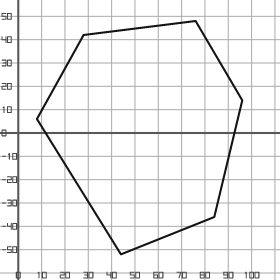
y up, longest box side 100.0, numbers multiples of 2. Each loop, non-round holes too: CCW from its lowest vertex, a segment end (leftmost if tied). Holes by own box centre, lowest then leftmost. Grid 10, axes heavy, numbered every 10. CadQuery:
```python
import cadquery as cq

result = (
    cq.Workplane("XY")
    .moveTo(44.0, -52.0)
    .lineTo(84.0, -36.0)
    .lineTo(96.0, 14.0)
    .lineTo(76.0, 48.0)
    .lineTo(28.0, 42.0)
    .lineTo(8.0, 6.0)
    .close()
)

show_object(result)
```